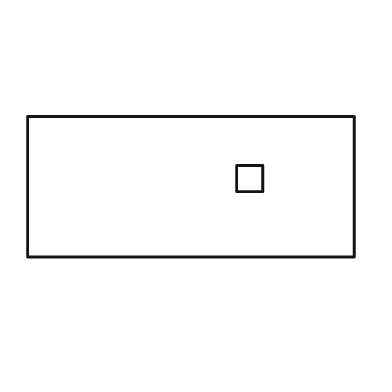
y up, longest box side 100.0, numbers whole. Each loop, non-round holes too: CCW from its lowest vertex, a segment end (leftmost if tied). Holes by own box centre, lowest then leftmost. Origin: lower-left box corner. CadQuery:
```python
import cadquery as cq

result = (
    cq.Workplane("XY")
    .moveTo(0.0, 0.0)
    .lineTo(100.0, 0.0)
    .lineTo(100.0, 43.0)
    .lineTo(0.0, 43.0)
    .close()
    .moveTo(64.0, 20.0)
    .lineTo(72.0, 20.0)
    .lineTo(72.0, 28.0)
    .lineTo(64.0, 28.0)
    .close()
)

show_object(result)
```